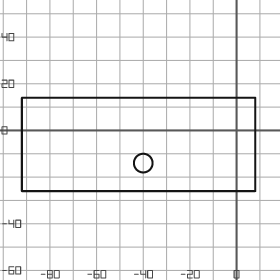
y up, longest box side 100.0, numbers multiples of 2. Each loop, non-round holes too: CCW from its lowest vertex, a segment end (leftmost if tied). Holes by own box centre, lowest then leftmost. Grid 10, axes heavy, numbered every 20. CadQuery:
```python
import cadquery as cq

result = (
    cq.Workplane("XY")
    .moveTo(-92.0, -26.0)
    .lineTo(8.0, -26.0)
    .lineTo(8.0, 14.0)
    .lineTo(-92.0, 14.0)
    .close()
    .moveTo(-40.0, -14.0)
    .circle(4.0)
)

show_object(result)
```